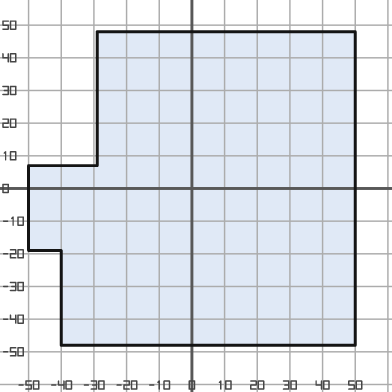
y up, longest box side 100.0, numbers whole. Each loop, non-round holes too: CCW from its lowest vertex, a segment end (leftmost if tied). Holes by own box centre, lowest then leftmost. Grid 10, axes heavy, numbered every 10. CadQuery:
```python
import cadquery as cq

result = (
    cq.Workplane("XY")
    .moveTo(-40.0, -48.0)
    .lineTo(50.0, -48.0)
    .lineTo(50.0, 48.0)
    .lineTo(-29.0, 48.0)
    .lineTo(-29.0, 7.0)
    .lineTo(-50.0, 7.0)
    .lineTo(-50.0, -19.0)
    .lineTo(-40.0, -19.0)
    .close()
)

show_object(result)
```